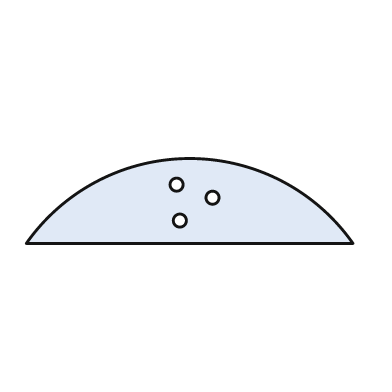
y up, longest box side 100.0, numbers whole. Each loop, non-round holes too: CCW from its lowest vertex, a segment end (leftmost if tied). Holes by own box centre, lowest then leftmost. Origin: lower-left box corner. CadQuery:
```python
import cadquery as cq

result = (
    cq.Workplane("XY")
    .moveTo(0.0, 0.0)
    .lineTo(100.0, 0.0)
    .threePointArc((50.0, 26.0), (0.0, 0.0))
    .close()
    .moveTo(47.0, 7.0)
    .circle(2.0)
    .moveTo(57.0, 14.0)
    .circle(2.0)
    .moveTo(46.0, 18.0)
    .circle(2.0)
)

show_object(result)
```